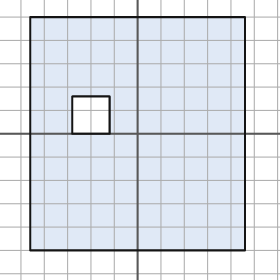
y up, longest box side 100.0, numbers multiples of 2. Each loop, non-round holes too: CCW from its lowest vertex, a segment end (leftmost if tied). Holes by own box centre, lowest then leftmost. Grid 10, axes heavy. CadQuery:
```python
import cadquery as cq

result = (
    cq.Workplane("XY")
    .moveTo(-46.0, -50.0)
    .lineTo(46.0, -50.0)
    .lineTo(46.0, 50.0)
    .lineTo(-46.0, 50.0)
    .close()
    .moveTo(-28.0, 0.0)
    .lineTo(-12.0, 0.0)
    .lineTo(-12.0, 16.0)
    .lineTo(-28.0, 16.0)
    .close()
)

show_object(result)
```